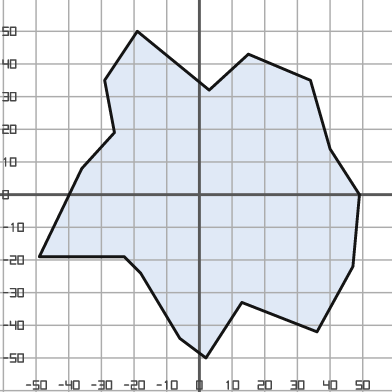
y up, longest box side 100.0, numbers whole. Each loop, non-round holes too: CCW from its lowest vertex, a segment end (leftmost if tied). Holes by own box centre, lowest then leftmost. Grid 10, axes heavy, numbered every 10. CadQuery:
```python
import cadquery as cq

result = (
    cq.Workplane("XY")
    .moveTo(2.0, -50.0)
    .lineTo(13.0, -33.0)
    .lineTo(36.0, -42.0)
    .lineTo(47.0, -22.0)
    .lineTo(49.0, 0.0)
    .lineTo(40.0, 14.0)
    .lineTo(34.0, 35.0)
    .lineTo(15.0, 43.0)
    .lineTo(3.0, 32.0)
    .lineTo(-19.0, 50.0)
    .lineTo(-29.0, 35.0)
    .lineTo(-26.0, 19.0)
    .lineTo(-36.0, 8.0)
    .lineTo(-49.0, -19.0)
    .lineTo(-23.0, -19.0)
    .lineTo(-18.0, -24.0)
    .lineTo(-6.0, -44.0)
    .close()
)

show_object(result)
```